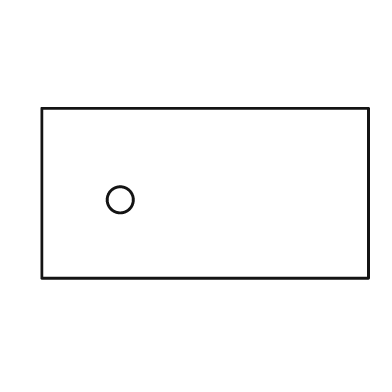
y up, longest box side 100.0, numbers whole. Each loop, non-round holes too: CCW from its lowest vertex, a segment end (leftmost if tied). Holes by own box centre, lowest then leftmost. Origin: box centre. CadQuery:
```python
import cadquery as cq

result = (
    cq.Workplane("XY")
    .moveTo(-50.0, -26.0)
    .lineTo(50.0, -26.0)
    .lineTo(50.0, 26.0)
    .lineTo(-50.0, 26.0)
    .close()
    .moveTo(-26.0, -2.0)
    .circle(4.0)
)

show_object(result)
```